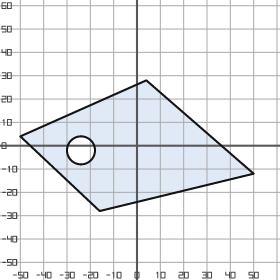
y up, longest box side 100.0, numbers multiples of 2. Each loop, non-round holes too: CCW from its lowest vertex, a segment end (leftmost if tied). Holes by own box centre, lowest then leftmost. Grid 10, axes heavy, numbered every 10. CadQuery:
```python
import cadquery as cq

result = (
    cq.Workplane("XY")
    .moveTo(-16.0, -28.0)
    .lineTo(50.0, -12.0)
    .lineTo(4.0, 28.0)
    .lineTo(-50.0, 4.0)
    .close()
    .moveTo(-24.0, -2.0)
    .circle(6.0)
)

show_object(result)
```